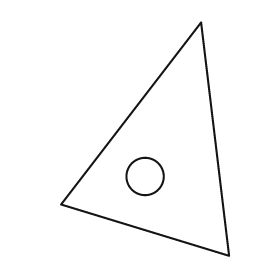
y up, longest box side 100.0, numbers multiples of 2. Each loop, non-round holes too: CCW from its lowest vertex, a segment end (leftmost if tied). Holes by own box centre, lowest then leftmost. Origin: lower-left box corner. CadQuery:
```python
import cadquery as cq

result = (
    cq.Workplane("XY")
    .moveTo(72.0, 0.0)
    .lineTo(60.0, 100.0)
    .lineTo(0.0, 22.0)
    .close()
    .moveTo(36.0, 34.0)
    .circle(8.0)
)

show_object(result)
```